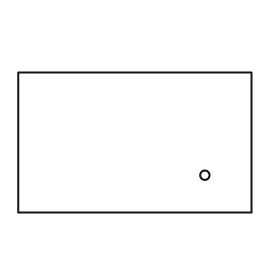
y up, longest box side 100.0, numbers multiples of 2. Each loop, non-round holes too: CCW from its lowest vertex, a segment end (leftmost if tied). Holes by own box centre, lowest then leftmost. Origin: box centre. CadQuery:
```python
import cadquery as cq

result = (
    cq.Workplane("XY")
    .moveTo(-50.0, -30.0)
    .lineTo(50.0, -30.0)
    .lineTo(50.0, 30.0)
    .lineTo(-50.0, 30.0)
    .close()
    .moveTo(30.0, -14.0)
    .circle(2.0)
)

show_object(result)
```